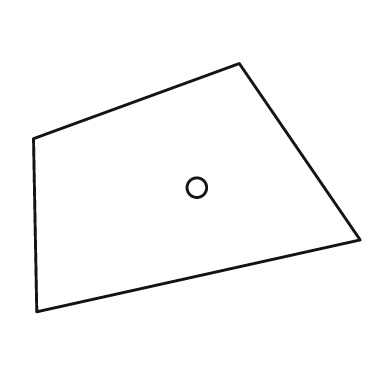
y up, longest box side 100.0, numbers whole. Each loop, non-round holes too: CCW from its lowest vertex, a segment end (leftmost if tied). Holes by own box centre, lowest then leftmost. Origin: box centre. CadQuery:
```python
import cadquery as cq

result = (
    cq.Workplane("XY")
    .moveTo(-49.0, -38.0)
    .lineTo(50.0, -16.0)
    .lineTo(13.0, 38.0)
    .lineTo(-50.0, 15.0)
    .close()
    .moveTo(0.0, 0.0)
    .circle(3.0)
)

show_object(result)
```